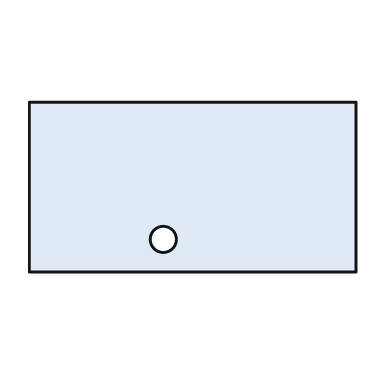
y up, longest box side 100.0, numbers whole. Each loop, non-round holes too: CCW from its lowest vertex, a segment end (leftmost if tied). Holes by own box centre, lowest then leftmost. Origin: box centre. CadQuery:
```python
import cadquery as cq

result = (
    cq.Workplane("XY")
    .moveTo(-50.0, -26.0)
    .lineTo(50.0, -26.0)
    .lineTo(50.0, 26.0)
    .lineTo(-50.0, 26.0)
    .close()
    .moveTo(-9.0, -16.0)
    .circle(4.0)
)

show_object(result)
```